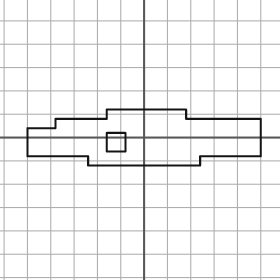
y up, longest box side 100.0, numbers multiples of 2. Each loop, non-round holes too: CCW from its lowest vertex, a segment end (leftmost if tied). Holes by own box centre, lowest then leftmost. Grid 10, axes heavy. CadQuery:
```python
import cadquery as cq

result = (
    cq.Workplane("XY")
    .moveTo(-24.0, -12.0)
    .lineTo(24.0, -12.0)
    .lineTo(24.0, -8.0)
    .lineTo(50.0, -8.0)
    .lineTo(50.0, 8.0)
    .lineTo(18.0, 8.0)
    .lineTo(18.0, 12.0)
    .lineTo(-16.0, 12.0)
    .lineTo(-16.0, 8.0)
    .lineTo(-38.0, 8.0)
    .lineTo(-38.0, 4.0)
    .lineTo(-50.0, 4.0)
    .lineTo(-50.0, -8.0)
    .lineTo(-24.0, -8.0)
    .close()
    .moveTo(-16.0, -6.0)
    .lineTo(-8.0, -6.0)
    .lineTo(-8.0, 2.0)
    .lineTo(-16.0, 2.0)
    .close()
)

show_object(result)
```